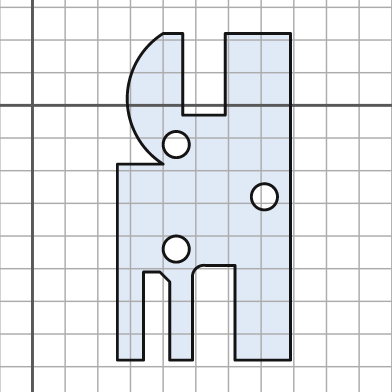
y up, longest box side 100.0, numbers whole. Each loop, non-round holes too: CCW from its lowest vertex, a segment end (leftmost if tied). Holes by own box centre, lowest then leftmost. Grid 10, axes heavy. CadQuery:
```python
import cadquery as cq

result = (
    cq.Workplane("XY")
    .moveTo(26.0, -78.0)
    .lineTo(34.0, -78.0)
    .lineTo(34.0, -51.0)
    .lineTo(39.0, -51.0)
    .lineTo(42.0, -54.0)
    .lineTo(42.0, -78.0)
    .lineTo(49.0, -78.0)
    .lineTo(49.0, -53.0)
    .threePointArc((50.0, -50.0), (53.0, -49.0))
    .lineTo(62.0, -49.0)
    .lineTo(62.0, -78.0)
    .lineTo(79.0, -78.0)
    .lineTo(79.0, 22.0)
    .lineTo(59.0, 22.0)
    .lineTo(59.0, -3.0)
    .lineTo(46.0, -3.0)
    .lineTo(46.0, 22.0)
    .lineTo(40.0, 22.0)
    .threePointArc((29.0, 2.0), (40.0, -18.0))
    .lineTo(26.0, -18.0)
    .close()
    .moveTo(44.0, -44.0)
    .circle(4.0)
    .moveTo(71.0, -28.0)
    .circle(4.0)
    .moveTo(44.0, -12.0)
    .circle(4.0)
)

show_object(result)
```